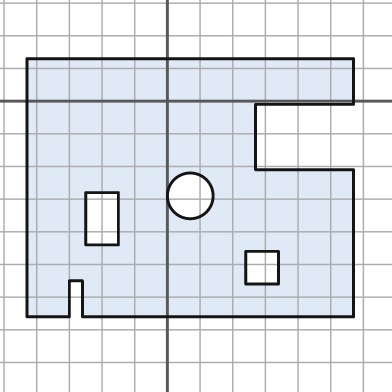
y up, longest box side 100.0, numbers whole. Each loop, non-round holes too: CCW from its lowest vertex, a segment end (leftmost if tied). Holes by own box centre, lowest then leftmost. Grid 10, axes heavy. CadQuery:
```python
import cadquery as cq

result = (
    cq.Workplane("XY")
    .moveTo(-43.0, -66.0)
    .lineTo(-30.0, -66.0)
    .lineTo(-30.0, -55.0)
    .lineTo(-26.0, -55.0)
    .lineTo(-26.0, -66.0)
    .lineTo(57.0, -66.0)
    .lineTo(57.0, -21.0)
    .lineTo(27.0, -21.0)
    .lineTo(27.0, -1.0)
    .lineTo(57.0, -1.0)
    .lineTo(57.0, 13.0)
    .lineTo(-43.0, 13.0)
    .close()
    .moveTo(24.0, -56.0)
    .lineTo(34.0, -56.0)
    .lineTo(34.0, -46.0)
    .lineTo(24.0, -46.0)
    .close()
    .moveTo(-25.0, -44.0)
    .lineTo(-15.0, -44.0)
    .lineTo(-15.0, -28.0)
    .lineTo(-25.0, -28.0)
    .close()
    .moveTo(7.0, -29.0)
    .circle(7.0)
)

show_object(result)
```